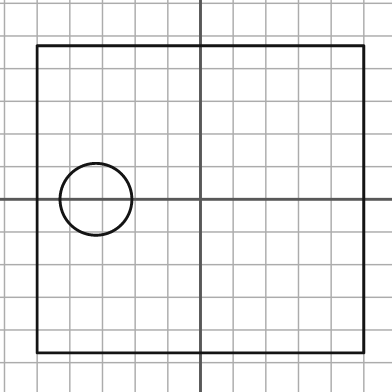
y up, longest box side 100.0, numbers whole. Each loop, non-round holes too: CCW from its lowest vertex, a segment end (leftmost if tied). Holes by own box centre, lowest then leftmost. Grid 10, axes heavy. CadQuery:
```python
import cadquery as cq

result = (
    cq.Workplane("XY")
    .moveTo(-50.0, -47.0)
    .lineTo(50.0, -47.0)
    .lineTo(50.0, 47.0)
    .lineTo(-50.0, 47.0)
    .close()
    .moveTo(-32.0, 0.0)
    .circle(11.0)
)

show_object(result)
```